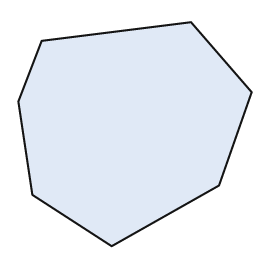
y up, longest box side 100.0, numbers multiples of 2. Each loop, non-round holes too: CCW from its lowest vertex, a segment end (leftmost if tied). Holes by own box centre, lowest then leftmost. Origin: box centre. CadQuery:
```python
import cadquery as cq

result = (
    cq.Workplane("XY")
    .moveTo(-10.0, -48.0)
    .lineTo(36.0, -22.0)
    .lineTo(50.0, 18.0)
    .lineTo(24.0, 48.0)
    .lineTo(-40.0, 40.0)
    .lineTo(-50.0, 14.0)
    .lineTo(-44.0, -26.0)
    .close()
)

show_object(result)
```